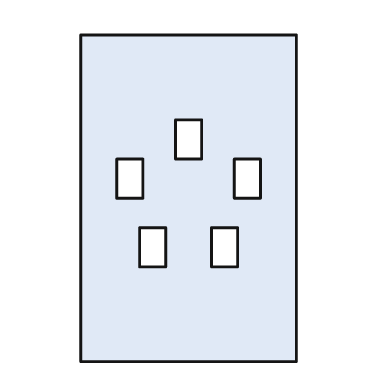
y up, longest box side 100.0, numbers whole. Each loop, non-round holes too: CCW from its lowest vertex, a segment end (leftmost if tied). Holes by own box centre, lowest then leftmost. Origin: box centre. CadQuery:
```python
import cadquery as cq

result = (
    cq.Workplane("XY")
    .moveTo(-33.0, -50.0)
    .lineTo(33.0, -50.0)
    .lineTo(33.0, 50.0)
    .lineTo(-33.0, 50.0)
    .close()
    .moveTo(-15.0, -21.0)
    .lineTo(-7.0, -21.0)
    .lineTo(-7.0, -9.0)
    .lineTo(-15.0, -9.0)
    .close()
    .moveTo(7.0, -21.0)
    .lineTo(15.0, -21.0)
    .lineTo(15.0, -9.0)
    .lineTo(7.0, -9.0)
    .close()
    .moveTo(-22.0, 0.0)
    .lineTo(-14.0, 0.0)
    .lineTo(-14.0, 12.0)
    .lineTo(-22.0, 12.0)
    .close()
    .moveTo(14.0, 0.0)
    .lineTo(22.0, 0.0)
    .lineTo(22.0, 12.0)
    .lineTo(14.0, 12.0)
    .close()
    .moveTo(-4.0, 12.0)
    .lineTo(4.0, 12.0)
    .lineTo(4.0, 24.0)
    .lineTo(-4.0, 24.0)
    .close()
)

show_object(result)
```